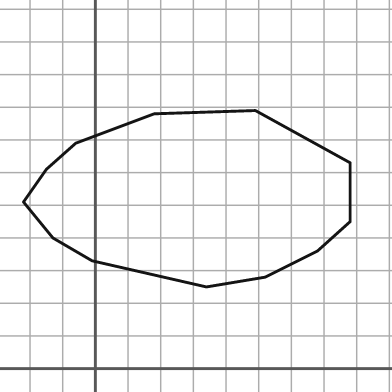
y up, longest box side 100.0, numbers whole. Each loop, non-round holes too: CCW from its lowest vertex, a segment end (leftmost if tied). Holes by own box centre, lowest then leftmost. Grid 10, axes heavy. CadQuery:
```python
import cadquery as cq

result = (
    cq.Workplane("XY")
    .moveTo(34.0, 25.0)
    .lineTo(52.0, 28.0)
    .lineTo(68.0, 36.0)
    .lineTo(78.0, 45.0)
    .lineTo(78.0, 63.0)
    .lineTo(49.0, 79.0)
    .lineTo(18.0, 78.0)
    .lineTo(-6.0, 69.0)
    .lineTo(-15.0, 61.0)
    .lineTo(-22.0, 51.0)
    .lineTo(-13.0, 40.0)
    .lineTo(-1.0, 33.0)
    .close()
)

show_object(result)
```